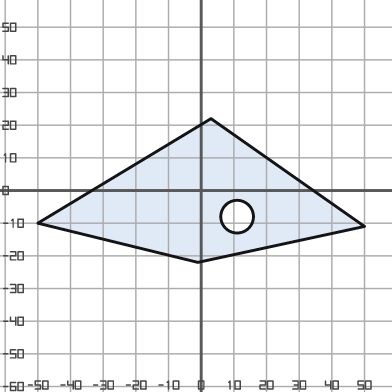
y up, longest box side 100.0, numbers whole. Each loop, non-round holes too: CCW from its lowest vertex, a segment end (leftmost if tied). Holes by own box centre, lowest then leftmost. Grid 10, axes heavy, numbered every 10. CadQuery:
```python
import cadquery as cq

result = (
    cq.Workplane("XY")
    .moveTo(-1.0, -22.0)
    .lineTo(50.0, -11.0)
    .lineTo(3.0, 22.0)
    .lineTo(-50.0, -10.0)
    .close()
    .moveTo(11.0, -8.0)
    .circle(5.0)
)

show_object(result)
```